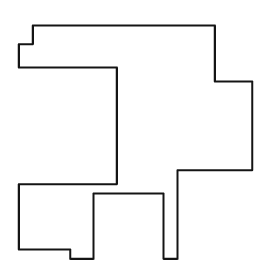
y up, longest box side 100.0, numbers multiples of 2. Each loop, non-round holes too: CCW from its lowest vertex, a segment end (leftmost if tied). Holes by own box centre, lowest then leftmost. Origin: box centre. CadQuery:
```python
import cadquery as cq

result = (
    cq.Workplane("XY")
    .moveTo(-28.0, -50.0)
    .lineTo(-18.0, -50.0)
    .lineTo(-18.0, -22.0)
    .lineTo(12.0, -22.0)
    .lineTo(12.0, -50.0)
    .lineTo(18.0, -50.0)
    .lineTo(18.0, -12.0)
    .lineTo(50.0, -12.0)
    .lineTo(50.0, 26.0)
    .lineTo(34.0, 26.0)
    .lineTo(34.0, 50.0)
    .lineTo(-44.0, 50.0)
    .lineTo(-44.0, 42.0)
    .lineTo(-50.0, 42.0)
    .lineTo(-50.0, 32.0)
    .lineTo(-8.0, 32.0)
    .lineTo(-8.0, -18.0)
    .lineTo(-50.0, -18.0)
    .lineTo(-50.0, -46.0)
    .lineTo(-28.0, -46.0)
    .close()
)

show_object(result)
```